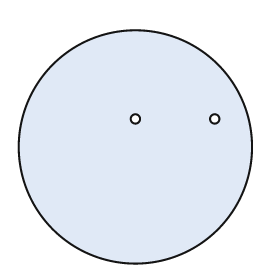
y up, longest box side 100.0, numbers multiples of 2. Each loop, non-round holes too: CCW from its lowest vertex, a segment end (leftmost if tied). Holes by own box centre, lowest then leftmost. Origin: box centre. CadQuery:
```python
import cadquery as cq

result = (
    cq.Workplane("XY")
    .moveTo(0.0, 0.0)
    .circle(50.0)
    .moveTo(0.0, 12.0)
    .circle(2.0)
    .moveTo(34.0, 12.0)
    .circle(2.0)
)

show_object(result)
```